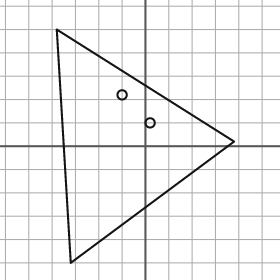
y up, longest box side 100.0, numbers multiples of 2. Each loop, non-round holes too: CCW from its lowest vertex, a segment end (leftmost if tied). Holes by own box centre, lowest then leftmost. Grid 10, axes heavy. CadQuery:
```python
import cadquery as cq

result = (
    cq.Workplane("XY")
    .moveTo(-32.0, -50.0)
    .lineTo(38.0, 2.0)
    .lineTo(-38.0, 50.0)
    .close()
    .moveTo(2.0, 10.0)
    .circle(2.0)
    .moveTo(-10.0, 22.0)
    .circle(2.0)
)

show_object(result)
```